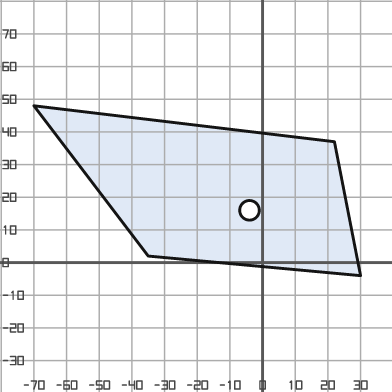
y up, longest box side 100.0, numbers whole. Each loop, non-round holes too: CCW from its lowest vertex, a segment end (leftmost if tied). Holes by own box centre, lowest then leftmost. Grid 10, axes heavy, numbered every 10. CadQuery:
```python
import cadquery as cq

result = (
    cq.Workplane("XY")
    .moveTo(30.0, -4.0)
    .lineTo(22.0, 37.0)
    .lineTo(-70.0, 48.0)
    .lineTo(-35.0, 2.0)
    .close()
    .moveTo(-4.0, 16.0)
    .circle(3.0)
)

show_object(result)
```